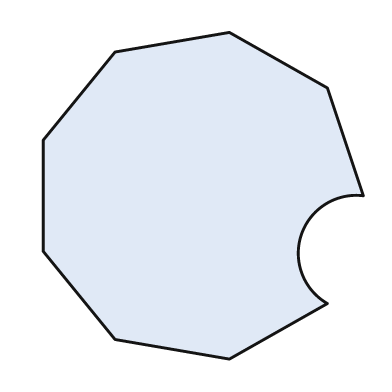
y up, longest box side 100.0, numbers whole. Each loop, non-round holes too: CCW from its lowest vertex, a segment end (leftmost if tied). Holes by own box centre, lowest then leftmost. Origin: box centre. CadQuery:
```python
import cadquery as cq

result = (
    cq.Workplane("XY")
    .moveTo(8.0, -50.0)
    .lineTo(38.0, -33.0)
    .threePointArc((30.0, -12.0), (49.0, 0.0))
    .lineTo(38.0, 33.0)
    .lineTo(8.0, 50.0)
    .lineTo(-27.0, 44.0)
    .lineTo(-49.0, 17.0)
    .lineTo(-49.0, -17.0)
    .lineTo(-27.0, -44.0)
    .close()
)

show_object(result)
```